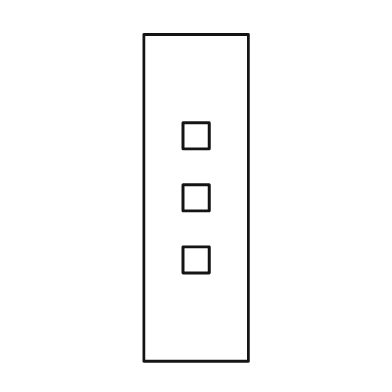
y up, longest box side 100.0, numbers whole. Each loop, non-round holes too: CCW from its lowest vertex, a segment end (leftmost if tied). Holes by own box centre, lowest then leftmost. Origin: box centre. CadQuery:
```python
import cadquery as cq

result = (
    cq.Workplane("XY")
    .moveTo(-16.0, -50.0)
    .lineTo(16.0, -50.0)
    .lineTo(16.0, 50.0)
    .lineTo(-16.0, 50.0)
    .close()
    .moveTo(-4.0, -23.0)
    .lineTo(4.0, -23.0)
    .lineTo(4.0, -15.0)
    .lineTo(-4.0, -15.0)
    .close()
    .moveTo(-4.0, -4.0)
    .lineTo(4.0, -4.0)
    .lineTo(4.0, 4.0)
    .lineTo(-4.0, 4.0)
    .close()
    .moveTo(-4.0, 15.0)
    .lineTo(4.0, 15.0)
    .lineTo(4.0, 23.0)
    .lineTo(-4.0, 23.0)
    .close()
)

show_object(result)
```